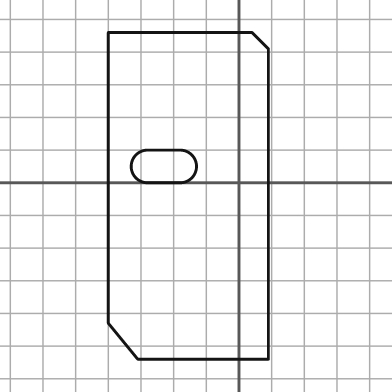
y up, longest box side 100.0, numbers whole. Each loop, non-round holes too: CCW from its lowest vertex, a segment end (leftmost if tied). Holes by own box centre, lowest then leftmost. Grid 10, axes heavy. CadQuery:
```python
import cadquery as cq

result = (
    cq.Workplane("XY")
    .moveTo(-31.0, -54.0)
    .lineTo(9.0, -54.0)
    .lineTo(9.0, 41.0)
    .lineTo(4.0, 46.0)
    .lineTo(-40.0, 46.0)
    .lineTo(-40.0, -43.0)
    .close()
    .moveTo(-28.0, 0.0)
    .lineTo(-18.0, 0.0)
    .threePointArc((-13.0, 5.0), (-18.0, 10.0))
    .lineTo(-28.0, 10.0)
    .threePointArc((-33.0, 5.0), (-28.0, 0.0))
    .close()
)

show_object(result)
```